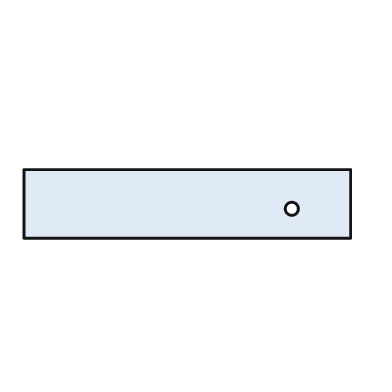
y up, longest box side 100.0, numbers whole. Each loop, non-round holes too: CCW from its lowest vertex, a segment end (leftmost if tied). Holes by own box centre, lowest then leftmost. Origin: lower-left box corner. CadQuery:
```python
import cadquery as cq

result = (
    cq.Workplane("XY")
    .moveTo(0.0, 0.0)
    .lineTo(100.0, 0.0)
    .lineTo(100.0, 21.0)
    .lineTo(0.0, 21.0)
    .close()
    .moveTo(82.0, 9.0)
    .circle(2.0)
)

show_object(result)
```